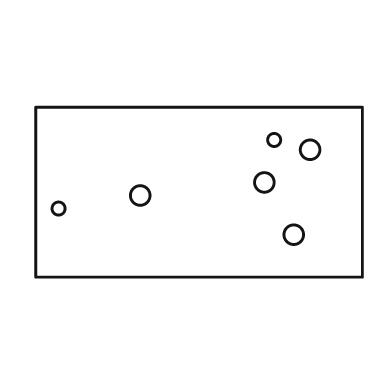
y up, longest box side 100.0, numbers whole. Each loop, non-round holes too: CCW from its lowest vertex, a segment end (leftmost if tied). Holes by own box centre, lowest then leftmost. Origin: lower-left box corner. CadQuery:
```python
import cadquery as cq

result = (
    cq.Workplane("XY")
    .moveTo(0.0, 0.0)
    .lineTo(100.0, 0.0)
    .lineTo(100.0, 52.0)
    .lineTo(0.0, 52.0)
    .close()
    .moveTo(79.0, 13.0)
    .circle(3.0)
    .moveTo(7.0, 21.0)
    .circle(2.0)
    .moveTo(32.0, 25.0)
    .circle(3.0)
    .moveTo(70.0, 29.0)
    .circle(3.0)
    .moveTo(84.0, 39.0)
    .circle(3.0)
    .moveTo(73.0, 42.0)
    .circle(2.0)
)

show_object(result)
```